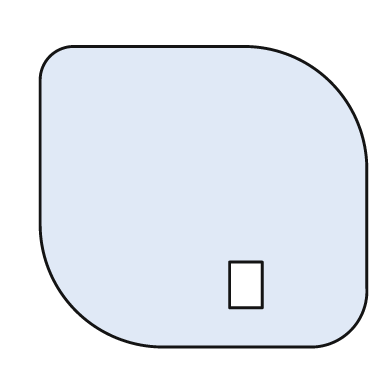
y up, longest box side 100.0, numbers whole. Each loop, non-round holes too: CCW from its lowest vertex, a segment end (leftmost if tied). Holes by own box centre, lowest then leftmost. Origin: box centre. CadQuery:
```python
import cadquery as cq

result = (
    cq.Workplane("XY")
    .moveTo(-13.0, -46.0)
    .lineTo(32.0, -46.0)
    .threePointArc((45.0, -41.0), (50.0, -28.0))
    .lineTo(50.0, 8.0)
    .threePointArc((39.0, 35.0), (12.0, 46.0))
    .lineTo(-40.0, 46.0)
    .threePointArc((-47.0, 43.0), (-50.0, 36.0))
    .lineTo(-50.0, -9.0)
    .threePointArc((-39.0, -35.0), (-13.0, -46.0))
    .close()
    .moveTo(8.0, -34.0)
    .lineTo(18.0, -34.0)
    .lineTo(18.0, -20.0)
    .lineTo(8.0, -20.0)
    .close()
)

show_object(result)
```